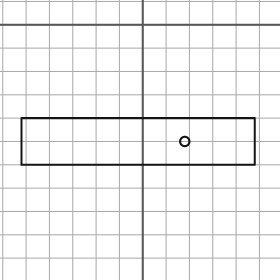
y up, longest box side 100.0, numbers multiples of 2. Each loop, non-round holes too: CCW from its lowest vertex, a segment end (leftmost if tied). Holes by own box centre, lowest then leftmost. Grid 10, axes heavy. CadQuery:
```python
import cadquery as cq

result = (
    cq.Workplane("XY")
    .moveTo(-52.0, -60.0)
    .lineTo(48.0, -60.0)
    .lineTo(48.0, -40.0)
    .lineTo(-52.0, -40.0)
    .close()
    .moveTo(18.0, -50.0)
    .circle(2.0)
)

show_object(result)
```